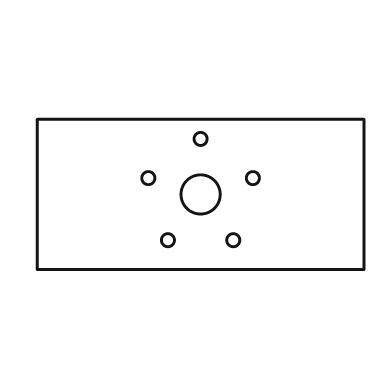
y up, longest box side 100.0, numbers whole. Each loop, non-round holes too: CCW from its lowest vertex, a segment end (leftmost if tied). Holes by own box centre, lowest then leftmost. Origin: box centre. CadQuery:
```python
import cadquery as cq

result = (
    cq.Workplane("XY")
    .moveTo(-50.0, -23.0)
    .lineTo(50.0, -23.0)
    .lineTo(50.0, 23.0)
    .lineTo(-50.0, 23.0)
    .close()
    .moveTo(-10.0, -14.0)
    .circle(2.0)
    .moveTo(10.0, -14.0)
    .circle(2.0)
    .moveTo(0.0, 0.0)
    .circle(6.0)
    .moveTo(-16.0, 5.0)
    .circle(2.0)
    .moveTo(16.0, 5.0)
    .circle(2.0)
    .moveTo(0.0, 17.0)
    .circle(2.0)
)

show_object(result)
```